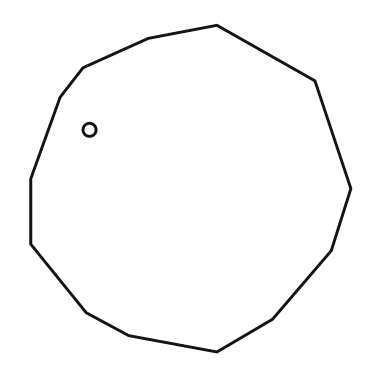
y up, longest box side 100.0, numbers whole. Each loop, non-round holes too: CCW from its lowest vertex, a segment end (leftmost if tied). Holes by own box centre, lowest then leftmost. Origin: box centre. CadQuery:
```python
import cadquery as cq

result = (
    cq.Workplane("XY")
    .moveTo(8.0, -50.0)
    .lineTo(25.0, -40.0)
    .lineTo(43.0, -19.0)
    .lineTo(49.0, 0.0)
    .lineTo(38.0, 33.0)
    .lineTo(8.0, 50.0)
    .lineTo(-13.0, 46.0)
    .lineTo(-33.0, 37.0)
    .lineTo(-40.0, 28.0)
    .lineTo(-49.0, 3.0)
    .lineTo(-49.0, -17.0)
    .lineTo(-32.0, -38.0)
    .lineTo(-19.0, -45.0)
    .close()
    .moveTo(-31.0, 18.0)
    .circle(2.0)
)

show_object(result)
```